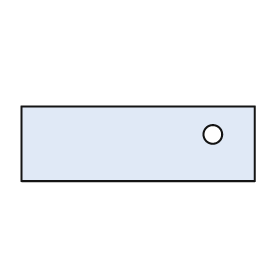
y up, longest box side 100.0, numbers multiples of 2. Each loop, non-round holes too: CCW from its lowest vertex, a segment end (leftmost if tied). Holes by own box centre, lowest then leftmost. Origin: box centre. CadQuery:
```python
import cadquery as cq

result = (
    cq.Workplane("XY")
    .moveTo(-50.0, -16.0)
    .lineTo(50.0, -16.0)
    .lineTo(50.0, 16.0)
    .lineTo(-50.0, 16.0)
    .close()
    .moveTo(32.0, 4.0)
    .circle(4.0)
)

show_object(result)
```